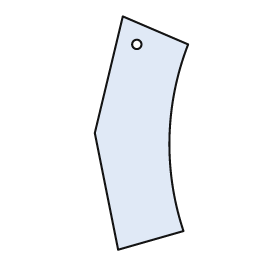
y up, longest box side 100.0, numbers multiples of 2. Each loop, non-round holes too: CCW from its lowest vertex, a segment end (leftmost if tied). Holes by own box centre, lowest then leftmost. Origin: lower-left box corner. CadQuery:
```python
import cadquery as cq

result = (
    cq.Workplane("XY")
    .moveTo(10.0, 0.0)
    .lineTo(38.0, 8.0)
    .threePointArc((32.0, 48.0), (40.0, 88.0))
    .lineTo(12.0, 100.0)
    .lineTo(0.0, 50.0)
    .close()
    .moveTo(18.0, 88.0)
    .circle(2.0)
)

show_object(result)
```